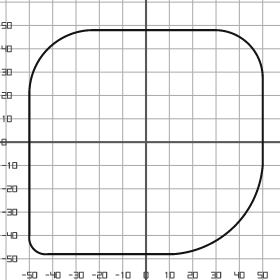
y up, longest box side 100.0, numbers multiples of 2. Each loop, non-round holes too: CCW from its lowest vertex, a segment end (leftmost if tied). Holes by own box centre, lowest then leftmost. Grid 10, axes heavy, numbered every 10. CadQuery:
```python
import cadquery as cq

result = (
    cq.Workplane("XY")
    .moveTo(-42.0, -48.0)
    .lineTo(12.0, -48.0)
    .threePointArc((38.0, -36.0), (50.0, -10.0))
    .lineTo(50.0, 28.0)
    .threePointArc((44.0, 42.0), (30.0, 48.0))
    .lineTo(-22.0, 48.0)
    .threePointArc((-42.0, 40.0), (-50.0, 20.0))
    .lineTo(-50.0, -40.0)
    .threePointArc((-48.0, -46.0), (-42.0, -48.0))
    .close()
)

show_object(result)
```